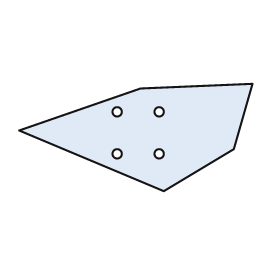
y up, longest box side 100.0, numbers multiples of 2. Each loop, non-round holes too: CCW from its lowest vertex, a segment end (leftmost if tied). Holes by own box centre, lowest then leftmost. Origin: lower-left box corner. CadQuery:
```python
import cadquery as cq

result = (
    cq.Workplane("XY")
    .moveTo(62.0, 0.0)
    .lineTo(92.0, 18.0)
    .lineTo(100.0, 46.0)
    .lineTo(52.0, 44.0)
    .lineTo(0.0, 26.0)
    .close()
    .moveTo(42.0, 16.0)
    .circle(2.0)
    .moveTo(60.0, 16.0)
    .circle(2.0)
    .moveTo(42.0, 34.0)
    .circle(2.0)
    .moveTo(60.0, 34.0)
    .circle(2.0)
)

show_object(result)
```